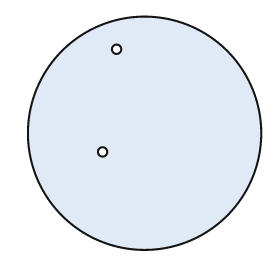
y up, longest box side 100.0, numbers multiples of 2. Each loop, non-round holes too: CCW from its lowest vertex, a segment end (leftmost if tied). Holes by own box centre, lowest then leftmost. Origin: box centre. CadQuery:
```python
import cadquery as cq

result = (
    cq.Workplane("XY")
    .moveTo(0.0, 0.0)
    .circle(50.0)
    .moveTo(-18.0, -8.0)
    .circle(2.0)
    .moveTo(-12.0, 36.0)
    .circle(2.0)
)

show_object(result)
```